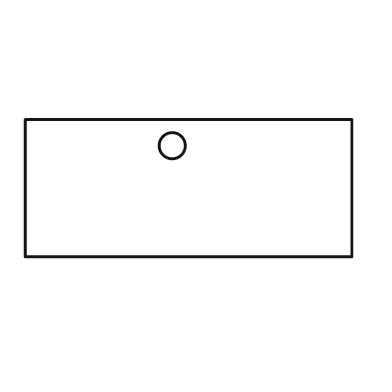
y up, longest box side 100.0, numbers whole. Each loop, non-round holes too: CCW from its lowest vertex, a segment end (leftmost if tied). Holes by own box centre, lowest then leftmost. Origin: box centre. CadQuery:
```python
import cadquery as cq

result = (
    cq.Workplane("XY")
    .moveTo(-50.0, -21.0)
    .lineTo(50.0, -21.0)
    .lineTo(50.0, 21.0)
    .lineTo(-50.0, 21.0)
    .close()
    .moveTo(-5.0, 13.0)
    .circle(4.0)
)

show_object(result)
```